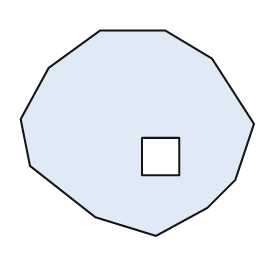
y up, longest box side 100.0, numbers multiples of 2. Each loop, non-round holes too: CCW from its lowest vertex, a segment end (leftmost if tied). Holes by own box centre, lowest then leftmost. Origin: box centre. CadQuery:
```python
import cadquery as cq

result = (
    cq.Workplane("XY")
    .moveTo(8.0, -44.0)
    .lineTo(30.0, -32.0)
    .lineTo(42.0, -20.0)
    .lineTo(50.0, 4.0)
    .lineTo(32.0, 32.0)
    .lineTo(12.0, 44.0)
    .lineTo(-16.0, 44.0)
    .lineTo(-38.0, 28.0)
    .lineTo(-50.0, 6.0)
    .lineTo(-46.0, -14.0)
    .lineTo(-18.0, -36.0)
    .close()
    .moveTo(2.0, -18.0)
    .lineTo(18.0, -18.0)
    .lineTo(18.0, -2.0)
    .lineTo(2.0, -2.0)
    .close()
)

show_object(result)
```